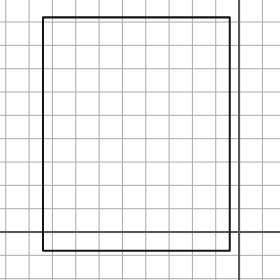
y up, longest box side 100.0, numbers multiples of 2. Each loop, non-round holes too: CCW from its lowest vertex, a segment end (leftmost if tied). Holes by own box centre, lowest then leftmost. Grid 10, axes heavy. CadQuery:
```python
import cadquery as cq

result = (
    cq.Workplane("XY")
    .moveTo(-84.0, -8.0)
    .lineTo(-4.0, -8.0)
    .lineTo(-4.0, 92.0)
    .lineTo(-84.0, 92.0)
    .close()
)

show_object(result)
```